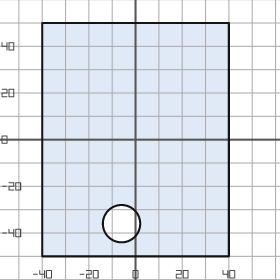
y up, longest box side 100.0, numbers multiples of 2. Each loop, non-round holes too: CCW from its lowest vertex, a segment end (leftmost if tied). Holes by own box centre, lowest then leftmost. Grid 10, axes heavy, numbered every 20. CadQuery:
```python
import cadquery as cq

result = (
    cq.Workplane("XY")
    .moveTo(-40.0, -50.0)
    .lineTo(40.0, -50.0)
    .lineTo(40.0, 50.0)
    .lineTo(-40.0, 50.0)
    .close()
    .moveTo(-6.0, -36.0)
    .circle(8.0)
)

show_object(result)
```